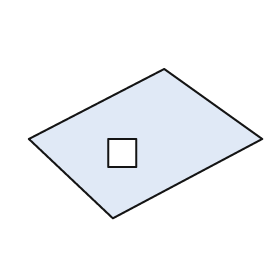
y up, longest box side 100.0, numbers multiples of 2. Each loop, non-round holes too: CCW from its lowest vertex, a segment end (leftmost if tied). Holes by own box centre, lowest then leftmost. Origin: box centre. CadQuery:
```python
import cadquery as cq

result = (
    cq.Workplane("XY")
    .moveTo(-14.0, -32.0)
    .lineTo(50.0, 2.0)
    .lineTo(8.0, 32.0)
    .lineTo(-50.0, 2.0)
    .close()
    .moveTo(-16.0, -10.0)
    .lineTo(-4.0, -10.0)
    .lineTo(-4.0, 2.0)
    .lineTo(-16.0, 2.0)
    .close()
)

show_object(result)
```